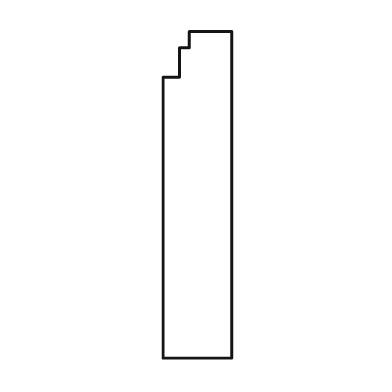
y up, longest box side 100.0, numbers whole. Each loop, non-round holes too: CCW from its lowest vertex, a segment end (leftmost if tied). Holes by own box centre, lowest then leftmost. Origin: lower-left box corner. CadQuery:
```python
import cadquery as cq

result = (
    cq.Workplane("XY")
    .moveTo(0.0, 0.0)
    .lineTo(21.0, 0.0)
    .lineTo(21.0, 100.0)
    .lineTo(8.0, 100.0)
    .lineTo(8.0, 95.0)
    .lineTo(5.0, 95.0)
    .lineTo(5.0, 86.0)
    .lineTo(0.0, 86.0)
    .close()
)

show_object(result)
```